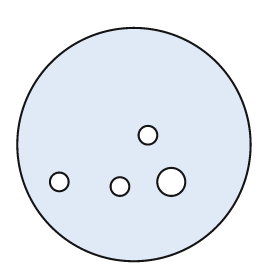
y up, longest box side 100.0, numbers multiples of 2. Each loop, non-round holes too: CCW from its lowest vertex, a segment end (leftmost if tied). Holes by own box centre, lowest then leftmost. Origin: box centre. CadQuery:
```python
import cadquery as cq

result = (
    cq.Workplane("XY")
    .moveTo(0.0, 0.0)
    .circle(50.0)
    .moveTo(-6.0, -18.0)
    .circle(4.0)
    .moveTo(-32.0, -16.0)
    .circle(4.0)
    .moveTo(16.0, -16.0)
    .circle(6.0)
    .moveTo(6.0, 4.0)
    .circle(4.0)
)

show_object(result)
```